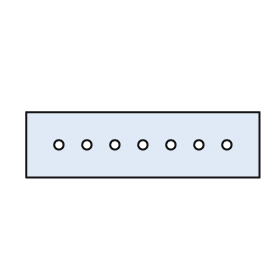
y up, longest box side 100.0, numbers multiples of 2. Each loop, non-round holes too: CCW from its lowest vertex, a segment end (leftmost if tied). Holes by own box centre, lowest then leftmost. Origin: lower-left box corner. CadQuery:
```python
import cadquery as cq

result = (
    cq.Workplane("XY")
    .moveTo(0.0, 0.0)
    .lineTo(100.0, 0.0)
    .lineTo(100.0, 28.0)
    .lineTo(0.0, 28.0)
    .close()
    .moveTo(14.0, 14.0)
    .circle(2.0)
    .moveTo(26.0, 14.0)
    .circle(2.0)
    .moveTo(38.0, 14.0)
    .circle(2.0)
    .moveTo(50.0, 14.0)
    .circle(2.0)
    .moveTo(62.0, 14.0)
    .circle(2.0)
    .moveTo(74.0, 14.0)
    .circle(2.0)
    .moveTo(86.0, 14.0)
    .circle(2.0)
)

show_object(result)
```